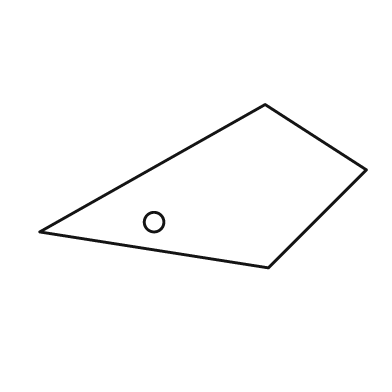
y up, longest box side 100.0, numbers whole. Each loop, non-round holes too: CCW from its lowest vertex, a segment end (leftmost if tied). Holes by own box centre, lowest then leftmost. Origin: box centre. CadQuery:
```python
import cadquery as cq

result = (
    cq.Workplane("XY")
    .moveTo(20.0, -25.0)
    .lineTo(50.0, 5.0)
    .lineTo(19.0, 25.0)
    .lineTo(-50.0, -14.0)
    .close()
    .moveTo(-15.0, -11.0)
    .circle(3.0)
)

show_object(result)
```